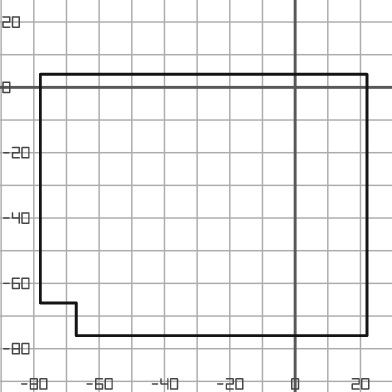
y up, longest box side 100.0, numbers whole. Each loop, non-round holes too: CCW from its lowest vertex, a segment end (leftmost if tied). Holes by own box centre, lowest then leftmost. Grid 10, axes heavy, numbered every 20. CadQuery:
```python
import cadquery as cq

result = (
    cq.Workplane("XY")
    .moveTo(-67.0, -76.0)
    .lineTo(22.0, -76.0)
    .lineTo(22.0, 4.0)
    .lineTo(-78.0, 4.0)
    .lineTo(-78.0, -66.0)
    .lineTo(-67.0, -66.0)
    .close()
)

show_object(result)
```